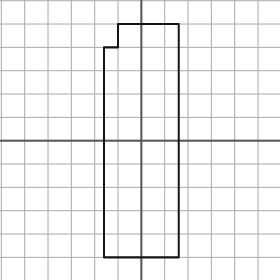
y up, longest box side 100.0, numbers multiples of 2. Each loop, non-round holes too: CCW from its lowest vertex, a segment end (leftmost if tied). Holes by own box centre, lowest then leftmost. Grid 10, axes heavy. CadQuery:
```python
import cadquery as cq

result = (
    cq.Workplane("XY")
    .moveTo(-16.0, -50.0)
    .lineTo(16.0, -50.0)
    .lineTo(16.0, 50.0)
    .lineTo(-10.0, 50.0)
    .lineTo(-10.0, 40.0)
    .lineTo(-16.0, 40.0)
    .close()
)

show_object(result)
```